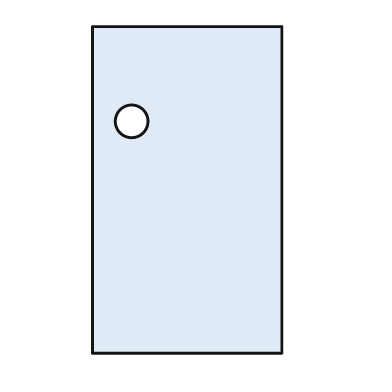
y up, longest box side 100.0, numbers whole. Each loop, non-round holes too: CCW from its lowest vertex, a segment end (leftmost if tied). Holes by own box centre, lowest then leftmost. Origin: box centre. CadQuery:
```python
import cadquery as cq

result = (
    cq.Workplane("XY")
    .moveTo(-29.0, -50.0)
    .lineTo(29.0, -50.0)
    .lineTo(29.0, 50.0)
    .lineTo(-29.0, 50.0)
    .close()
    .moveTo(-17.0, 21.0)
    .circle(5.0)
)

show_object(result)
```